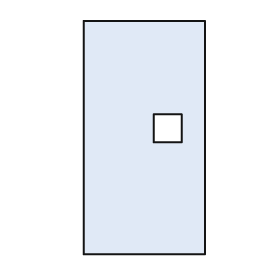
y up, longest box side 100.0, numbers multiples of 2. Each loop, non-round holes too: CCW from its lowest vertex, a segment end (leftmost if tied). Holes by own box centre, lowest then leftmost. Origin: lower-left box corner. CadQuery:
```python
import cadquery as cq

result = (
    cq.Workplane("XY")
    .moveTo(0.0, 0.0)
    .lineTo(52.0, 0.0)
    .lineTo(52.0, 100.0)
    .lineTo(0.0, 100.0)
    .close()
    .moveTo(30.0, 48.0)
    .lineTo(42.0, 48.0)
    .lineTo(42.0, 60.0)
    .lineTo(30.0, 60.0)
    .close()
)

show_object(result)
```